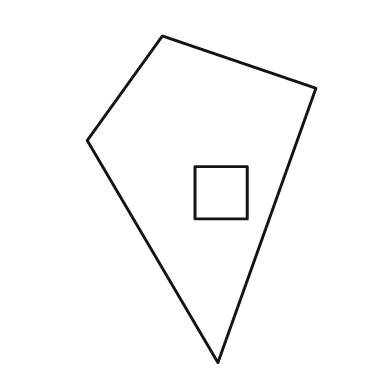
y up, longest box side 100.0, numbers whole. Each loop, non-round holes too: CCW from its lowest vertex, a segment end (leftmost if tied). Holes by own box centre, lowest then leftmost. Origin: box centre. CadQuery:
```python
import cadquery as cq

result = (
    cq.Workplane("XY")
    .moveTo(5.0, -50.0)
    .lineTo(35.0, 34.0)
    .lineTo(-12.0, 50.0)
    .lineTo(-35.0, 18.0)
    .close()
    .moveTo(-2.0, -6.0)
    .lineTo(14.0, -6.0)
    .lineTo(14.0, 10.0)
    .lineTo(-2.0, 10.0)
    .close()
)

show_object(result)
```